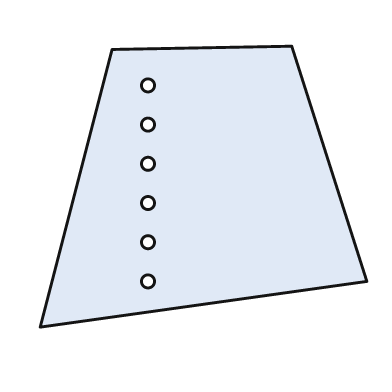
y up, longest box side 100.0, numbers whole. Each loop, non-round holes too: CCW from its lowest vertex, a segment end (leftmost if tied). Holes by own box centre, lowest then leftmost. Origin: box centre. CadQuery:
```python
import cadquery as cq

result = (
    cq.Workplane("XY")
    .moveTo(-50.0, -43.0)
    .lineTo(50.0, -29.0)
    .lineTo(27.0, 43.0)
    .lineTo(-28.0, 42.0)
    .close()
    .moveTo(-17.0, -29.0)
    .circle(2.0)
    .moveTo(-17.0, -17.0)
    .circle(2.0)
    .moveTo(-17.0, -5.0)
    .circle(2.0)
    .moveTo(-17.0, 7.0)
    .circle(2.0)
    .moveTo(-17.0, 19.0)
    .circle(2.0)
    .moveTo(-17.0, 31.0)
    .circle(2.0)
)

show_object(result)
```